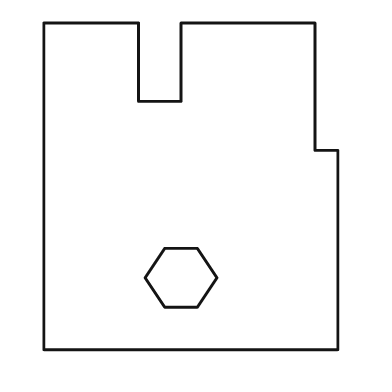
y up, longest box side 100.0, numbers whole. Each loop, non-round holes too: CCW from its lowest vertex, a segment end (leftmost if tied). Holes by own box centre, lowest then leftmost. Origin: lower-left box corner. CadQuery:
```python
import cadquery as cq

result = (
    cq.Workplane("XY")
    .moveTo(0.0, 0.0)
    .lineTo(90.0, 0.0)
    .lineTo(90.0, 61.0)
    .lineTo(83.0, 61.0)
    .lineTo(83.0, 100.0)
    .lineTo(42.0, 100.0)
    .lineTo(42.0, 76.0)
    .lineTo(29.0, 76.0)
    .lineTo(29.0, 100.0)
    .lineTo(0.0, 100.0)
    .close()
    .moveTo(37.0, 13.0)
    .lineTo(47.0, 13.0)
    .lineTo(53.0, 22.0)
    .lineTo(47.0, 31.0)
    .lineTo(37.0, 31.0)
    .lineTo(31.0, 22.0)
    .close()
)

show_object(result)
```